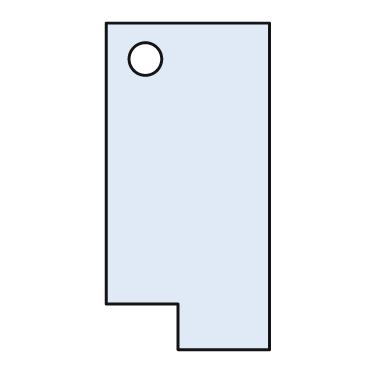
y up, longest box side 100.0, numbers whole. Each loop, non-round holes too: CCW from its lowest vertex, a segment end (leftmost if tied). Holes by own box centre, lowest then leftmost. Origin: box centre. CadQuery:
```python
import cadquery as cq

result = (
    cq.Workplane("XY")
    .moveTo(-3.0, -50.0)
    .lineTo(25.0, -50.0)
    .lineTo(25.0, 50.0)
    .lineTo(-25.0, 50.0)
    .lineTo(-25.0, -36.0)
    .lineTo(-3.0, -36.0)
    .close()
    .moveTo(-13.0, 39.0)
    .circle(5.0)
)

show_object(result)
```